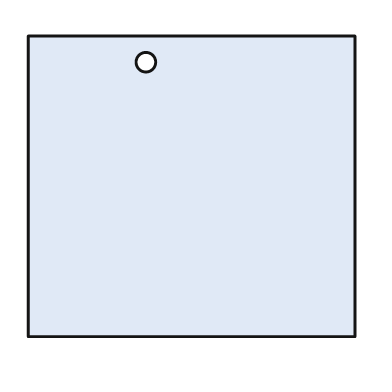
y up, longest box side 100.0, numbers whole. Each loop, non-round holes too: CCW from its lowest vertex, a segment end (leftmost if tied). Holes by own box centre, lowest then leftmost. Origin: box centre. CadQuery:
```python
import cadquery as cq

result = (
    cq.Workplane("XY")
    .moveTo(-50.0, -46.0)
    .lineTo(50.0, -46.0)
    .lineTo(50.0, 46.0)
    .lineTo(-50.0, 46.0)
    .close()
    .moveTo(-14.0, 38.0)
    .circle(3.0)
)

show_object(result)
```